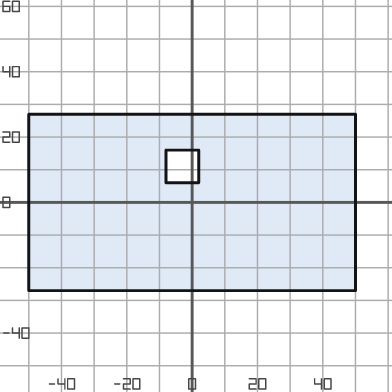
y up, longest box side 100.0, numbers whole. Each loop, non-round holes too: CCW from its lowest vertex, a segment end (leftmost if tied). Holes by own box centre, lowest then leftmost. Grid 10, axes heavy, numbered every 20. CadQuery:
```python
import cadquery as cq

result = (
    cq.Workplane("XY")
    .moveTo(-50.0, -27.0)
    .lineTo(50.0, -27.0)
    .lineTo(50.0, 27.0)
    .lineTo(-50.0, 27.0)
    .close()
    .moveTo(-8.0, 6.0)
    .lineTo(2.0, 6.0)
    .lineTo(2.0, 16.0)
    .lineTo(-8.0, 16.0)
    .close()
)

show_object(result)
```